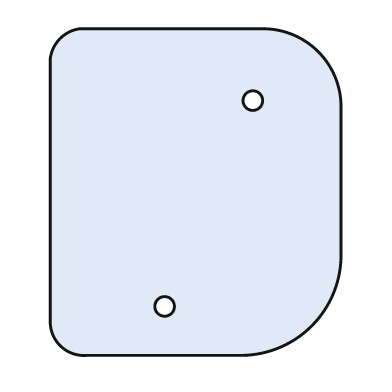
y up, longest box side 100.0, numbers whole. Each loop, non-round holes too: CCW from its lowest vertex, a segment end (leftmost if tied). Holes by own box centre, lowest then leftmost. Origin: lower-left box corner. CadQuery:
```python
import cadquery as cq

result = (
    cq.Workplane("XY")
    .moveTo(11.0, 0.0)
    .lineTo(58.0, 0.0)
    .threePointArc((80.0, 9.0), (89.0, 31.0))
    .lineTo(89.0, 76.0)
    .threePointArc((82.0, 93.0), (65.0, 100.0))
    .lineTo(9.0, 100.0)
    .threePointArc((3.0, 97.0), (0.0, 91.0))
    .lineTo(0.0, 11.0)
    .threePointArc((3.0, 3.0), (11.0, 0.0))
    .close()
    .moveTo(35.0, 15.0)
    .circle(3.0)
    .moveTo(62.0, 78.0)
    .circle(3.0)
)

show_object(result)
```